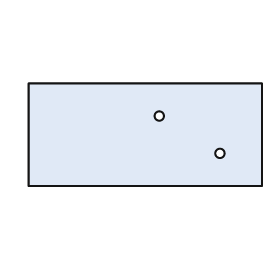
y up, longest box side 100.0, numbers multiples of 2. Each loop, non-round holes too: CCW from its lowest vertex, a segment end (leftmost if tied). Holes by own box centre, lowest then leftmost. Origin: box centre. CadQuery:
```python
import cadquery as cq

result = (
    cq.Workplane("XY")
    .moveTo(-50.0, -22.0)
    .lineTo(50.0, -22.0)
    .lineTo(50.0, 22.0)
    .lineTo(-50.0, 22.0)
    .close()
    .moveTo(32.0, -8.0)
    .circle(2.0)
    .moveTo(6.0, 8.0)
    .circle(2.0)
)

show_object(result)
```